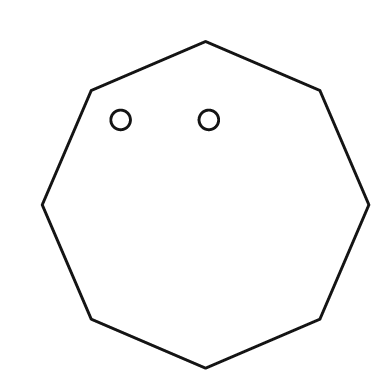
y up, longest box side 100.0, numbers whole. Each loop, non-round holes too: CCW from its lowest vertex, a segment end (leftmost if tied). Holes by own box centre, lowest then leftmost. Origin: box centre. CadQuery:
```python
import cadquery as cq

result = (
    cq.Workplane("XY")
    .moveTo(0.0, -50.0)
    .lineTo(35.0, -35.0)
    .lineTo(50.0, 0.0)
    .lineTo(35.0, 35.0)
    .lineTo(0.0, 50.0)
    .lineTo(-35.0, 35.0)
    .lineTo(-50.0, 0.0)
    .lineTo(-35.0, -35.0)
    .close()
    .moveTo(-26.0, 26.0)
    .circle(3.0)
    .moveTo(1.0, 26.0)
    .circle(3.0)
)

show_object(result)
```